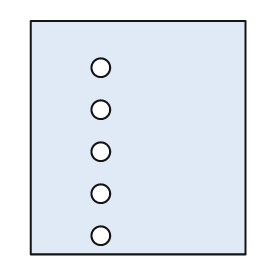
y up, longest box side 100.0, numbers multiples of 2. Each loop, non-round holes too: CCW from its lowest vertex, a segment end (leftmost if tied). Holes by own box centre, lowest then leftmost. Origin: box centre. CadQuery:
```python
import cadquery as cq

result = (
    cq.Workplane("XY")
    .moveTo(-46.0, -50.0)
    .lineTo(46.0, -50.0)
    .lineTo(46.0, 50.0)
    .lineTo(-46.0, 50.0)
    .close()
    .moveTo(-16.0, -42.0)
    .circle(4.0)
    .moveTo(-16.0, -24.0)
    .circle(4.0)
    .moveTo(-16.0, -6.0)
    .circle(4.0)
    .moveTo(-16.0, 12.0)
    .circle(4.0)
    .moveTo(-16.0, 30.0)
    .circle(4.0)
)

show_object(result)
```